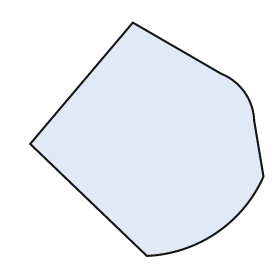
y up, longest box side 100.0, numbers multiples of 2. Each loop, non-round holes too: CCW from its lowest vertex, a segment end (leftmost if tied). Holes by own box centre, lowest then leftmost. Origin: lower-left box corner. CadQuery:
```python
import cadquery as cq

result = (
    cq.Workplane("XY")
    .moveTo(50.0, 0.0)
    .threePointArc((80.0, 10.0), (100.0, 34.0))
    .lineTo(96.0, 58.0)
    .threePointArc((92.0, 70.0), (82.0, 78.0))
    .lineTo(44.0, 100.0)
    .lineTo(0.0, 48.0)
    .close()
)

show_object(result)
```